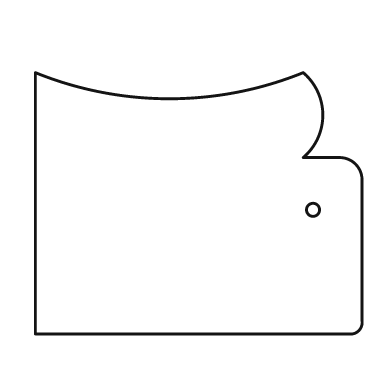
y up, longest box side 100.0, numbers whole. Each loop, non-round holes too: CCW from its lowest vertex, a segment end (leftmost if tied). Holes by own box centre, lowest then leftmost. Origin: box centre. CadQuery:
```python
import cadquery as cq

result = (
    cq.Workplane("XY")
    .moveTo(-50.0, -40.0)
    .lineTo(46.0, -40.0)
    .threePointArc((49.0, -39.0), (50.0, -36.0))
    .lineTo(50.0, 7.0)
    .threePointArc((48.0, 12.0), (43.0, 14.0))
    .lineTo(32.0, 14.0)
    .threePointArc((38.0, 27.0), (32.0, 40.0))
    .threePointArc((-9.0, 32.0), (-50.0, 40.0))
    .close()
    .moveTo(35.0, -2.0)
    .circle(2.0)
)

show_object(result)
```